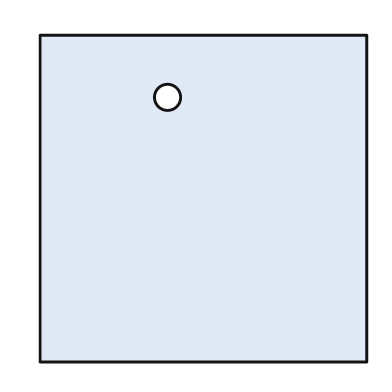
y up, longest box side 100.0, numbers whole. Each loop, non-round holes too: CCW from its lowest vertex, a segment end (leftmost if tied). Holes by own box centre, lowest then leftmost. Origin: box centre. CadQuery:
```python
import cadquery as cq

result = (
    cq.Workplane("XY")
    .moveTo(-50.0, -50.0)
    .lineTo(50.0, -50.0)
    .lineTo(50.0, 50.0)
    .lineTo(-50.0, 50.0)
    .close()
    .moveTo(-11.0, 31.0)
    .circle(4.0)
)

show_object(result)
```